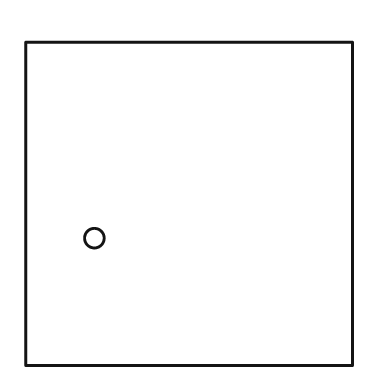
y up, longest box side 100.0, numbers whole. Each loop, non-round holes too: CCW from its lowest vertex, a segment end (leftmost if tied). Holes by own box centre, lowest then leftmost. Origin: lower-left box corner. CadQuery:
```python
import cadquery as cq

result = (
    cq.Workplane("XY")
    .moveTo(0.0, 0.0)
    .lineTo(100.0, 0.0)
    .lineTo(100.0, 99.0)
    .lineTo(0.0, 99.0)
    .close()
    .moveTo(21.0, 39.0)
    .circle(3.0)
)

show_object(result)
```